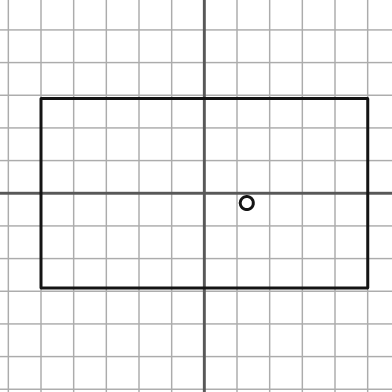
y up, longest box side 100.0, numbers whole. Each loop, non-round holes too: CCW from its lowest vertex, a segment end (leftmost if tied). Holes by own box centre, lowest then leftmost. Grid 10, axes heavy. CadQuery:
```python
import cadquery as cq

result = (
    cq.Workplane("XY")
    .moveTo(-50.0, -29.0)
    .lineTo(50.0, -29.0)
    .lineTo(50.0, 29.0)
    .lineTo(-50.0, 29.0)
    .close()
    .moveTo(13.0, -3.0)
    .circle(2.0)
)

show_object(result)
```